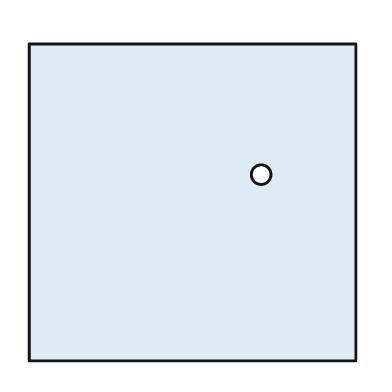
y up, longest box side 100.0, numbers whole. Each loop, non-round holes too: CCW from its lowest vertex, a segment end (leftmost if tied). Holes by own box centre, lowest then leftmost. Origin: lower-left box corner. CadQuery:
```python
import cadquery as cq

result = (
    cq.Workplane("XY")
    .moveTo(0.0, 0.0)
    .lineTo(100.0, 0.0)
    .lineTo(100.0, 97.0)
    .lineTo(0.0, 97.0)
    .close()
    .moveTo(71.0, 57.0)
    .circle(3.0)
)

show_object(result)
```